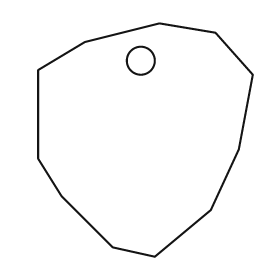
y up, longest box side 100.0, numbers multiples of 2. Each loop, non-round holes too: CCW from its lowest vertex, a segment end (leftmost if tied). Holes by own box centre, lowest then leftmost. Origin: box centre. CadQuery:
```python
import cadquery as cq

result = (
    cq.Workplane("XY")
    .moveTo(4.0, -50.0)
    .lineTo(28.0, -30.0)
    .lineTo(40.0, -4.0)
    .lineTo(46.0, 28.0)
    .lineTo(30.0, 46.0)
    .lineTo(6.0, 50.0)
    .lineTo(-26.0, 42.0)
    .lineTo(-46.0, 30.0)
    .lineTo(-46.0, -8.0)
    .lineTo(-36.0, -24.0)
    .lineTo(-14.0, -46.0)
    .close()
    .moveTo(-2.0, 34.0)
    .circle(6.0)
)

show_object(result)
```